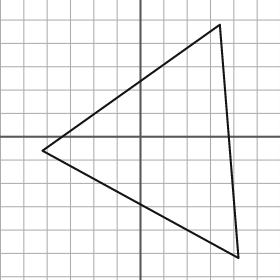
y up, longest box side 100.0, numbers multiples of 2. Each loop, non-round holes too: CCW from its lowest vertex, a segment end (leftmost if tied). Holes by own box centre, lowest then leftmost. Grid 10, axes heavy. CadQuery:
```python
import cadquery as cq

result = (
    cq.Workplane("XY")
    .moveTo(42.0, -52.0)
    .lineTo(34.0, 48.0)
    .lineTo(-42.0, -6.0)
    .close()
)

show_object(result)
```